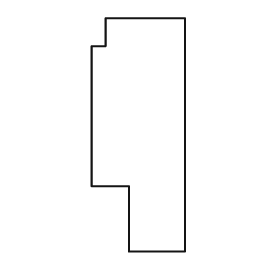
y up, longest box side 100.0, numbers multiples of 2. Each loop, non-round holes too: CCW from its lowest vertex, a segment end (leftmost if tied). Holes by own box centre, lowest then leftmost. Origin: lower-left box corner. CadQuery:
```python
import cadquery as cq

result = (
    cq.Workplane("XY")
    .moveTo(16.0, 0.0)
    .lineTo(40.0, 0.0)
    .lineTo(40.0, 100.0)
    .lineTo(6.0, 100.0)
    .lineTo(6.0, 88.0)
    .lineTo(0.0, 88.0)
    .lineTo(0.0, 28.0)
    .lineTo(16.0, 28.0)
    .close()
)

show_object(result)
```